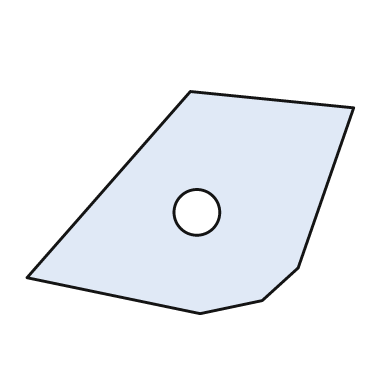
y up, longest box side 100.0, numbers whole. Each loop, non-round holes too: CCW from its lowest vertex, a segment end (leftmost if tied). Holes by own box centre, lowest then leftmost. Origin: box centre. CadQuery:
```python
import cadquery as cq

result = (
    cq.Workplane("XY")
    .moveTo(3.0, -34.0)
    .lineTo(22.0, -30.0)
    .lineTo(33.0, -20.0)
    .lineTo(50.0, 29.0)
    .lineTo(0.0, 34.0)
    .lineTo(-50.0, -23.0)
    .close()
    .moveTo(2.0, -3.0)
    .circle(7.0)
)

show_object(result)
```